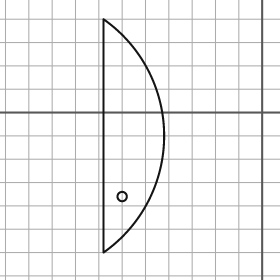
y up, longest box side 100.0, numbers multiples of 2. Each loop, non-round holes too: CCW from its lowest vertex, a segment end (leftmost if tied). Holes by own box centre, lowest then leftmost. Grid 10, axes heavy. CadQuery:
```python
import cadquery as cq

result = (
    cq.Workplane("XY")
    .moveTo(-68.0, -60.0)
    .threePointArc((-42.0, -10.0), (-68.0, 40.0))
    .close()
    .moveTo(-60.0, -36.0)
    .circle(2.0)
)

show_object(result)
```